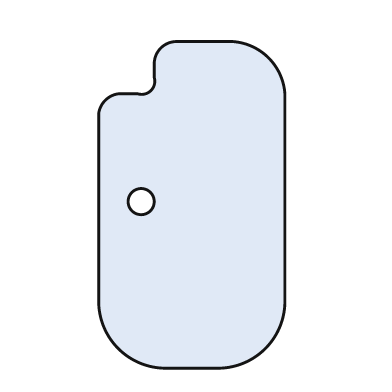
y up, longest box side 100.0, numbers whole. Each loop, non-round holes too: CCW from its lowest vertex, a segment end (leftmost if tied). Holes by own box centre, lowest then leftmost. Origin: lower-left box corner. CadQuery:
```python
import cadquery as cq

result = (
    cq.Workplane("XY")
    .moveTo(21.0, 0.0)
    .lineTo(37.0, 0.0)
    .threePointArc((51.0, 6.0), (57.0, 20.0))
    .lineTo(57.0, 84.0)
    .threePointArc((52.0, 95.0), (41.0, 100.0))
    .lineTo(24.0, 100.0)
    .threePointArc((19.0, 98.0), (17.0, 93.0))
    .lineTo(17.0, 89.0)
    .threePointArc((16.0, 85.0), (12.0, 84.0))
    .lineTo(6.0, 84.0)
    .threePointArc((2.0, 82.0), (0.0, 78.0))
    .lineTo(0.0, 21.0)
    .threePointArc((6.0, 6.0), (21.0, 0.0))
    .close()
    .moveTo(13.0, 51.0)
    .circle(4.0)
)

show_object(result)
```